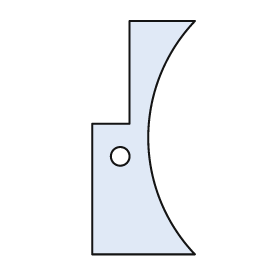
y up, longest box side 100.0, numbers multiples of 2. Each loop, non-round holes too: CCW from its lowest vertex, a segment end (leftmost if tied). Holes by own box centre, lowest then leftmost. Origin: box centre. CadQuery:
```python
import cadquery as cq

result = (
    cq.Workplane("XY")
    .moveTo(-22.0, -50.0)
    .lineTo(22.0, -50.0)
    .threePointArc((2.0, 0.0), (22.0, 50.0))
    .lineTo(-6.0, 50.0)
    .lineTo(-6.0, 6.0)
    .lineTo(-22.0, 6.0)
    .close()
    .moveTo(-10.0, -8.0)
    .circle(4.0)
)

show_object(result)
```